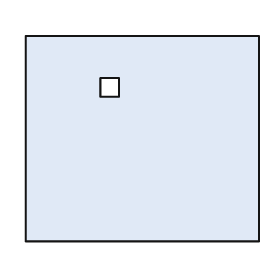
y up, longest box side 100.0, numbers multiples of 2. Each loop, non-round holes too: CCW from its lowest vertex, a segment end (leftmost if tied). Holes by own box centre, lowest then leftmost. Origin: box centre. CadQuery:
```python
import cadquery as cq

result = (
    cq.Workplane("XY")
    .moveTo(-50.0, -44.0)
    .lineTo(50.0, -44.0)
    .lineTo(50.0, 44.0)
    .lineTo(-50.0, 44.0)
    .close()
    .moveTo(-18.0, 18.0)
    .lineTo(-10.0, 18.0)
    .lineTo(-10.0, 26.0)
    .lineTo(-18.0, 26.0)
    .close()
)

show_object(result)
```